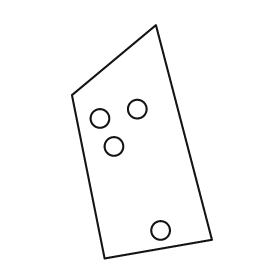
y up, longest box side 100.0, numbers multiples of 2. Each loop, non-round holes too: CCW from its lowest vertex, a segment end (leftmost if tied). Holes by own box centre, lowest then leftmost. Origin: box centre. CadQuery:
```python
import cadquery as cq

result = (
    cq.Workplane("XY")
    .moveTo(-16.0, -50.0)
    .lineTo(30.0, -42.0)
    .lineTo(6.0, 50.0)
    .lineTo(-30.0, 20.0)
    .close()
    .moveTo(8.0, -38.0)
    .circle(4.0)
    .moveTo(-12.0, -2.0)
    .circle(4.0)
    .moveTo(-18.0, 10.0)
    .circle(4.0)
    .moveTo(-2.0, 14.0)
    .circle(4.0)
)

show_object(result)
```